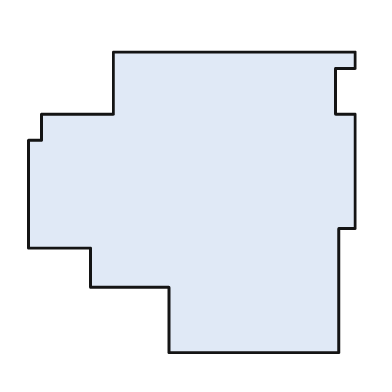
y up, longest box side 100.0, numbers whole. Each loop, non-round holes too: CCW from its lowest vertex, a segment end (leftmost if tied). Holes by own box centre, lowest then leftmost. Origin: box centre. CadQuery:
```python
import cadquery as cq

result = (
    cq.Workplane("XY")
    .moveTo(-7.0, -46.0)
    .lineTo(45.0, -46.0)
    .lineTo(45.0, -8.0)
    .lineTo(50.0, -8.0)
    .lineTo(50.0, 27.0)
    .lineTo(44.0, 27.0)
    .lineTo(44.0, 41.0)
    .lineTo(50.0, 41.0)
    .lineTo(50.0, 46.0)
    .lineTo(-24.0, 46.0)
    .lineTo(-24.0, 27.0)
    .lineTo(-46.0, 27.0)
    .lineTo(-46.0, 19.0)
    .lineTo(-50.0, 19.0)
    .lineTo(-50.0, -14.0)
    .lineTo(-31.0, -14.0)
    .lineTo(-31.0, -26.0)
    .lineTo(-7.0, -26.0)
    .close()
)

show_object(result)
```